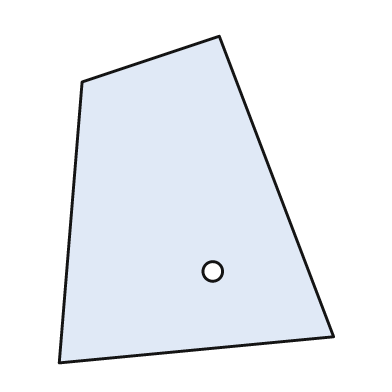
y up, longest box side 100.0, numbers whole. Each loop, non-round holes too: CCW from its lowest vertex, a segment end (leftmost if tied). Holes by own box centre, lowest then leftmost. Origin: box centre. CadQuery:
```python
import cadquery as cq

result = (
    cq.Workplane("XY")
    .moveTo(-42.0, -50.0)
    .lineTo(42.0, -42.0)
    .lineTo(7.0, 50.0)
    .lineTo(-35.0, 36.0)
    .close()
    .moveTo(5.0, -22.0)
    .circle(3.0)
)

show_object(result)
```